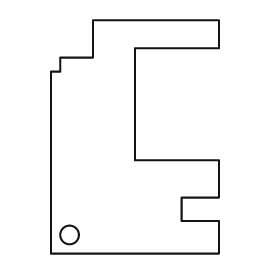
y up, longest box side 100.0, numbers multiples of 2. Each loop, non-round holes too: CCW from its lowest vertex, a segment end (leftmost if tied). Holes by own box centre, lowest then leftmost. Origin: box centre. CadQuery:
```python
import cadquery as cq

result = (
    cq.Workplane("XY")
    .moveTo(-36.0, -50.0)
    .lineTo(36.0, -50.0)
    .lineTo(36.0, -36.0)
    .lineTo(20.0, -36.0)
    .lineTo(20.0, -26.0)
    .lineTo(36.0, -26.0)
    .lineTo(36.0, -10.0)
    .lineTo(0.0, -10.0)
    .lineTo(0.0, 38.0)
    .lineTo(36.0, 38.0)
    .lineTo(36.0, 50.0)
    .lineTo(-18.0, 50.0)
    .lineTo(-18.0, 34.0)
    .lineTo(-32.0, 34.0)
    .lineTo(-32.0, 28.0)
    .lineTo(-36.0, 28.0)
    .close()
    .moveTo(-28.0, -42.0)
    .circle(4.0)
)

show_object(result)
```